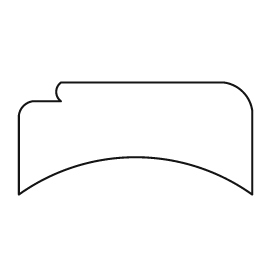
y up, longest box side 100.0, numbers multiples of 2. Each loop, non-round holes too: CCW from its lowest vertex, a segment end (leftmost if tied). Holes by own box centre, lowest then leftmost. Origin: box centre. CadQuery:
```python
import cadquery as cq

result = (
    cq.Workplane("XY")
    .moveTo(-50.0, -24.0)
    .threePointArc((0.0, -8.0), (50.0, -24.0))
    .lineTo(50.0, 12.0)
    .threePointArc((46.0, 20.0), (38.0, 24.0))
    .lineTo(-32.0, 24.0)
    .threePointArc((-34.0, 20.0), (-32.0, 16.0))
    .lineTo(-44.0, 16.0)
    .threePointArc((-48.0, 14.0), (-50.0, 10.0))
    .close()
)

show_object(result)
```